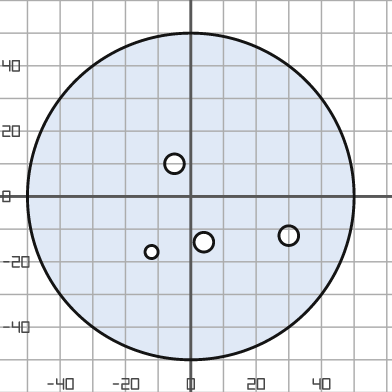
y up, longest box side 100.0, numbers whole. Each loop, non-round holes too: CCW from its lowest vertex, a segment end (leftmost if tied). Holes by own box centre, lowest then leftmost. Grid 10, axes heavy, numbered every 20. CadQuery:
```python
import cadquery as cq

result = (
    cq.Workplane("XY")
    .moveTo(0.0, 0.0)
    .circle(50.0)
    .moveTo(-12.0, -17.0)
    .circle(2.0)
    .moveTo(4.0, -14.0)
    .circle(3.0)
    .moveTo(30.0, -12.0)
    .circle(3.0)
    .moveTo(-5.0, 10.0)
    .circle(3.0)
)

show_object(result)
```